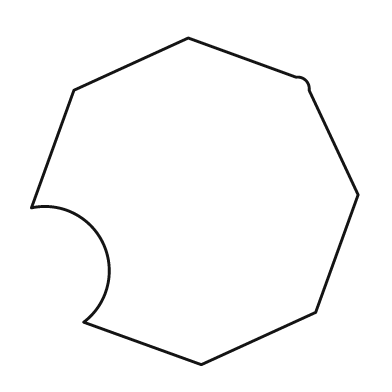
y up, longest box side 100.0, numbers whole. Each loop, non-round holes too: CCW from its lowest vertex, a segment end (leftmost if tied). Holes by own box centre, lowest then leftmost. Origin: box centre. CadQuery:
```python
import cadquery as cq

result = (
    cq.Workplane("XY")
    .moveTo(2.0, -50.0)
    .lineTo(37.0, -34.0)
    .lineTo(50.0, 2.0)
    .lineTo(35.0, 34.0)
    .threePointArc((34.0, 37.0), (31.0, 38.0))
    .lineTo(-2.0, 50.0)
    .lineTo(-37.0, 34.0)
    .lineTo(-50.0, -2.0)
    .threePointArc((-28.0, -13.0), (-34.0, -37.0))
    .close()
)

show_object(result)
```